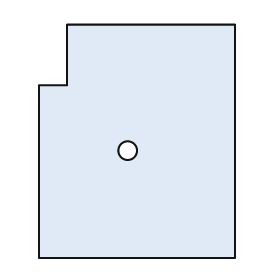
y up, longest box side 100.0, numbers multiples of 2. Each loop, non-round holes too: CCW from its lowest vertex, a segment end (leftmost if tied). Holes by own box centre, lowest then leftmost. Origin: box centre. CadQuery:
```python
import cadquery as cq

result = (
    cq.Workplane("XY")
    .moveTo(-42.0, -50.0)
    .lineTo(42.0, -50.0)
    .lineTo(42.0, 50.0)
    .lineTo(-30.0, 50.0)
    .lineTo(-30.0, 24.0)
    .lineTo(-42.0, 24.0)
    .close()
    .moveTo(-4.0, -4.0)
    .circle(4.0)
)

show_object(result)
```